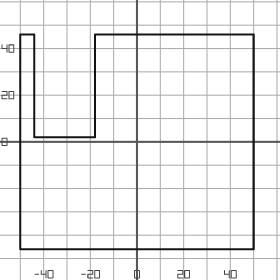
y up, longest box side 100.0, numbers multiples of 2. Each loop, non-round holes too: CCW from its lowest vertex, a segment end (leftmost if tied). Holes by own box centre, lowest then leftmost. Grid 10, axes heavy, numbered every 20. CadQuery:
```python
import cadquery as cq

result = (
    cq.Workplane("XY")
    .moveTo(-50.0, -46.0)
    .lineTo(50.0, -46.0)
    .lineTo(50.0, 46.0)
    .lineTo(-18.0, 46.0)
    .lineTo(-18.0, 2.0)
    .lineTo(-44.0, 2.0)
    .lineTo(-44.0, 46.0)
    .lineTo(-50.0, 46.0)
    .close()
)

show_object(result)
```